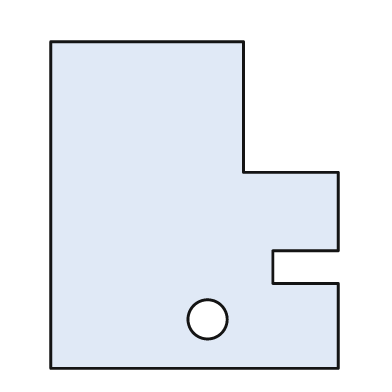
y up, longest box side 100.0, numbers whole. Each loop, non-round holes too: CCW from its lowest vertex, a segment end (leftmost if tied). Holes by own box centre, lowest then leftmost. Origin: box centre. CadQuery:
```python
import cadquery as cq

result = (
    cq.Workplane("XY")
    .moveTo(-44.0, -50.0)
    .lineTo(44.0, -50.0)
    .lineTo(44.0, -24.0)
    .lineTo(24.0, -24.0)
    .lineTo(24.0, -14.0)
    .lineTo(44.0, -14.0)
    .lineTo(44.0, 10.0)
    .lineTo(15.0, 10.0)
    .lineTo(15.0, 50.0)
    .lineTo(-44.0, 50.0)
    .close()
    .moveTo(4.0, -35.0)
    .circle(6.0)
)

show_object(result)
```